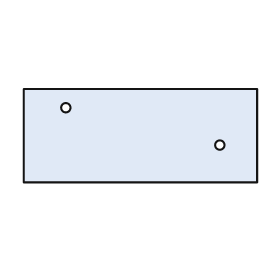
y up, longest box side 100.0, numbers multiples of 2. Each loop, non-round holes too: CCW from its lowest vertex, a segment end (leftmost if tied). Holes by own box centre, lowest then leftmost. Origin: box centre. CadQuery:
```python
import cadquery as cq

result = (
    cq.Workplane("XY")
    .moveTo(-50.0, -20.0)
    .lineTo(50.0, -20.0)
    .lineTo(50.0, 20.0)
    .lineTo(-50.0, 20.0)
    .close()
    .moveTo(34.0, -4.0)
    .circle(2.0)
    .moveTo(-32.0, 12.0)
    .circle(2.0)
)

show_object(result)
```